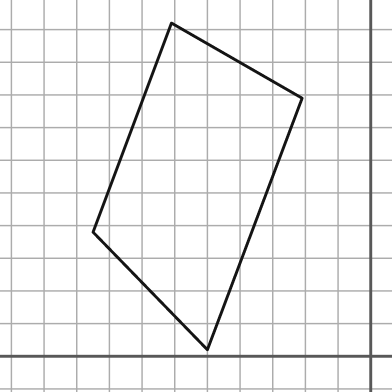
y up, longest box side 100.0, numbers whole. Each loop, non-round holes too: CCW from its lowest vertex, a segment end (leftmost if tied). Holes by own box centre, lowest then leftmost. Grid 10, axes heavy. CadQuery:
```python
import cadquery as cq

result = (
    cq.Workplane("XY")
    .moveTo(-50.0, 2.0)
    .lineTo(-21.0, 79.0)
    .lineTo(-61.0, 102.0)
    .lineTo(-85.0, 38.0)
    .close()
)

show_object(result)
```